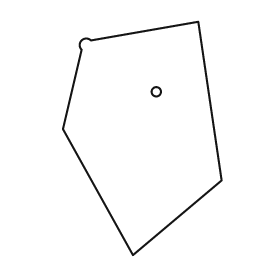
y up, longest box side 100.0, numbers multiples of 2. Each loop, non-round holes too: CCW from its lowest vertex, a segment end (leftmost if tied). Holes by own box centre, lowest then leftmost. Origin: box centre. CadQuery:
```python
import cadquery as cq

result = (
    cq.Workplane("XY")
    .moveTo(-4.0, -50.0)
    .lineTo(34.0, -18.0)
    .lineTo(24.0, 50.0)
    .lineTo(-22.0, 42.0)
    .threePointArc((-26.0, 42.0), (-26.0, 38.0))
    .lineTo(-34.0, 4.0)
    .close()
    .moveTo(6.0, 20.0)
    .circle(2.0)
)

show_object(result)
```